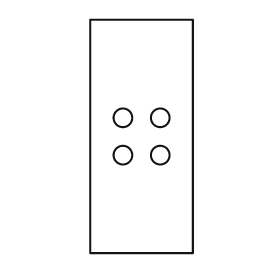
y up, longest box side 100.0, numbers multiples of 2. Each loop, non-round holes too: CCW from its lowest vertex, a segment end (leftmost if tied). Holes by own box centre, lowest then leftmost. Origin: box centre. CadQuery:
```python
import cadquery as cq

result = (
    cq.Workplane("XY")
    .moveTo(-22.0, -50.0)
    .lineTo(22.0, -50.0)
    .lineTo(22.0, 50.0)
    .lineTo(-22.0, 50.0)
    .close()
    .moveTo(-8.0, -8.0)
    .circle(4.0)
    .moveTo(8.0, -8.0)
    .circle(4.0)
    .moveTo(-8.0, 8.0)
    .circle(4.0)
    .moveTo(8.0, 8.0)
    .circle(4.0)
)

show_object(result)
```